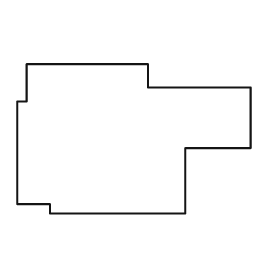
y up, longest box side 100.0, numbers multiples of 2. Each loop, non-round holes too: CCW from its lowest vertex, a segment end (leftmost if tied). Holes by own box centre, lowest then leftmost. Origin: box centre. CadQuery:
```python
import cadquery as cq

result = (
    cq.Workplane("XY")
    .moveTo(-36.0, -32.0)
    .lineTo(22.0, -32.0)
    .lineTo(22.0, -4.0)
    .lineTo(50.0, -4.0)
    .lineTo(50.0, 22.0)
    .lineTo(6.0, 22.0)
    .lineTo(6.0, 32.0)
    .lineTo(-46.0, 32.0)
    .lineTo(-46.0, 16.0)
    .lineTo(-50.0, 16.0)
    .lineTo(-50.0, -28.0)
    .lineTo(-36.0, -28.0)
    .close()
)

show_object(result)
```